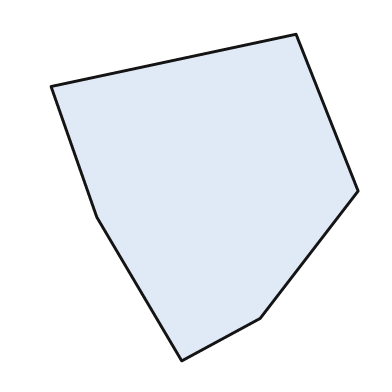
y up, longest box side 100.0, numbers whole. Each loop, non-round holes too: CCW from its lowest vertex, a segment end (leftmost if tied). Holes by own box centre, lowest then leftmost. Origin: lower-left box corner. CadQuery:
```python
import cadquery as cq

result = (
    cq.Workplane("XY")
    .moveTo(40.0, 0.0)
    .lineTo(64.0, 13.0)
    .lineTo(94.0, 52.0)
    .lineTo(75.0, 100.0)
    .lineTo(0.0, 84.0)
    .lineTo(14.0, 44.0)
    .close()
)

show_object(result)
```